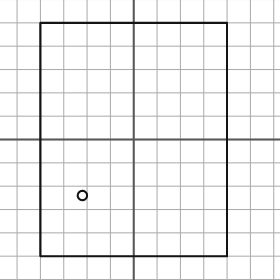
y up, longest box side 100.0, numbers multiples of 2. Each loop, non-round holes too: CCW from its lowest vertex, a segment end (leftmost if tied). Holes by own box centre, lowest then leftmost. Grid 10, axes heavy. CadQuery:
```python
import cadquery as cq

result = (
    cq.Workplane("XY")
    .moveTo(-40.0, -50.0)
    .lineTo(40.0, -50.0)
    .lineTo(40.0, 50.0)
    .lineTo(-40.0, 50.0)
    .close()
    .moveTo(-22.0, -24.0)
    .circle(2.0)
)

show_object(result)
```